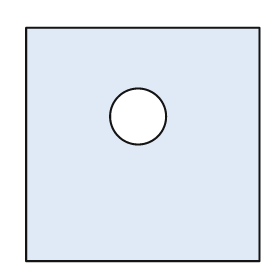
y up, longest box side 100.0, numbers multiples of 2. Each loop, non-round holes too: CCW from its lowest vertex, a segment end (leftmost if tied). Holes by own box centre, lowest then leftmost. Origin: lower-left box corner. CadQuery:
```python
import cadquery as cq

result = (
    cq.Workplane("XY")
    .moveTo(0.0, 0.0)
    .lineTo(100.0, 0.0)
    .lineTo(100.0, 100.0)
    .lineTo(0.0, 100.0)
    .close()
    .moveTo(48.0, 62.0)
    .circle(12.0)
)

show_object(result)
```